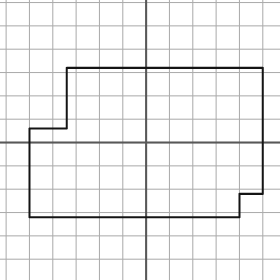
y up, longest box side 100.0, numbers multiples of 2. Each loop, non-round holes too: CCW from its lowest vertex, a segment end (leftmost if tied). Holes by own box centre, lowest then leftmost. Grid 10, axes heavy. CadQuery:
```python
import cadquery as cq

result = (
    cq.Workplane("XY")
    .moveTo(-50.0, -32.0)
    .lineTo(40.0, -32.0)
    .lineTo(40.0, -22.0)
    .lineTo(50.0, -22.0)
    .lineTo(50.0, 32.0)
    .lineTo(-34.0, 32.0)
    .lineTo(-34.0, 6.0)
    .lineTo(-50.0, 6.0)
    .close()
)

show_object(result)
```